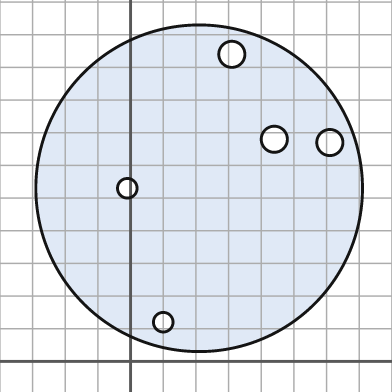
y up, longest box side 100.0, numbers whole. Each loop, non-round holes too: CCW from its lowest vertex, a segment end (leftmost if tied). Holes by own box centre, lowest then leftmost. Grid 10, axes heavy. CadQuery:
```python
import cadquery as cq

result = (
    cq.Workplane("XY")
    .moveTo(21.0, 53.0)
    .circle(50.0)
    .moveTo(10.0, 12.0)
    .circle(3.0)
    .moveTo(-1.0, 53.0)
    .circle(3.0)
    .moveTo(61.0, 67.0)
    .circle(4.0)
    .moveTo(44.0, 68.0)
    .circle(4.0)
    .moveTo(31.0, 94.0)
    .circle(4.0)
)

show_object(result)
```